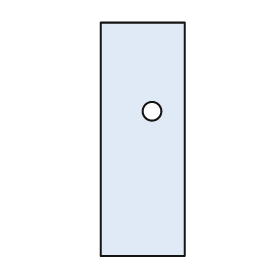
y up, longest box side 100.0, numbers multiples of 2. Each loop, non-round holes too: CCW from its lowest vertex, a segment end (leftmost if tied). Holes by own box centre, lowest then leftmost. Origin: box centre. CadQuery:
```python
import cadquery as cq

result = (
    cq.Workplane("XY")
    .moveTo(-18.0, -50.0)
    .lineTo(18.0, -50.0)
    .lineTo(18.0, 50.0)
    .lineTo(-18.0, 50.0)
    .close()
    .moveTo(4.0, 12.0)
    .circle(4.0)
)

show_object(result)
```